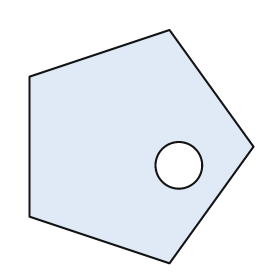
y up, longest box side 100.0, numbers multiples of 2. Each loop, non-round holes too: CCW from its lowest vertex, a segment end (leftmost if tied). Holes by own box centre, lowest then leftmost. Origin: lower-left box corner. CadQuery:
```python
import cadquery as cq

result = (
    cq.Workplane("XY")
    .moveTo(60.0, 0.0)
    .lineTo(96.0, 50.0)
    .lineTo(60.0, 100.0)
    .lineTo(0.0, 80.0)
    .lineTo(0.0, 20.0)
    .close()
    .moveTo(64.0, 42.0)
    .circle(10.0)
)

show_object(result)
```